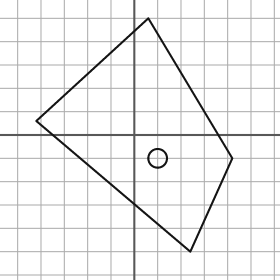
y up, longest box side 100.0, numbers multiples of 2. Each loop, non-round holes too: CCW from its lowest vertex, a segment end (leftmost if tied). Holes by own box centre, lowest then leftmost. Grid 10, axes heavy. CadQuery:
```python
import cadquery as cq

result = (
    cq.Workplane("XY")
    .moveTo(24.0, -50.0)
    .lineTo(42.0, -10.0)
    .lineTo(6.0, 50.0)
    .lineTo(-42.0, 6.0)
    .close()
    .moveTo(10.0, -10.0)
    .circle(4.0)
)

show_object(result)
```